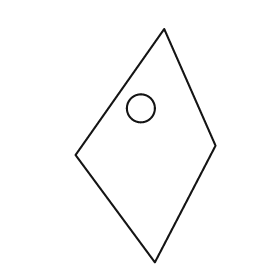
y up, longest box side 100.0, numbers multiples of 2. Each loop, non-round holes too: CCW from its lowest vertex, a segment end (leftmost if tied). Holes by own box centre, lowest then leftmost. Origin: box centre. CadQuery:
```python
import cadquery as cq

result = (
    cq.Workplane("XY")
    .moveTo(4.0, -50.0)
    .lineTo(30.0, 0.0)
    .lineTo(8.0, 50.0)
    .lineTo(-30.0, -4.0)
    .close()
    .moveTo(-2.0, 16.0)
    .circle(6.0)
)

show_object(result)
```